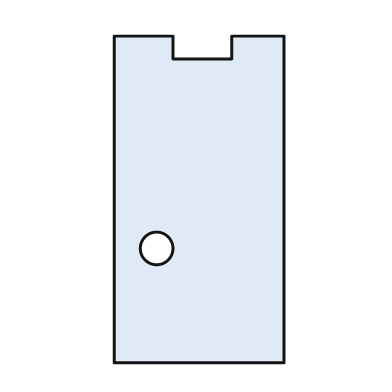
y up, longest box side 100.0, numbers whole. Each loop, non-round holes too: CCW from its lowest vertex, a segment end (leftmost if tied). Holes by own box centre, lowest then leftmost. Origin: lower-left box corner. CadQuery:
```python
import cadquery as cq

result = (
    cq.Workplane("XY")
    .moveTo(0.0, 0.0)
    .lineTo(52.0, 0.0)
    .lineTo(52.0, 100.0)
    .lineTo(36.0, 100.0)
    .lineTo(36.0, 93.0)
    .lineTo(18.0, 93.0)
    .lineTo(18.0, 100.0)
    .lineTo(0.0, 100.0)
    .close()
    .moveTo(13.0, 35.0)
    .circle(5.0)
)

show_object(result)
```